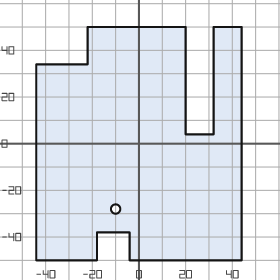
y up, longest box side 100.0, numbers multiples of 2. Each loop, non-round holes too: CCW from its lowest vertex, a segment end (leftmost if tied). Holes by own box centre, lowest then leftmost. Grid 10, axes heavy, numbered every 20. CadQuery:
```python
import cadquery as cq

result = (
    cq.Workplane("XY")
    .moveTo(-44.0, -50.0)
    .lineTo(-18.0, -50.0)
    .lineTo(-18.0, -38.0)
    .lineTo(-4.0, -38.0)
    .lineTo(-4.0, -50.0)
    .lineTo(44.0, -50.0)
    .lineTo(44.0, 50.0)
    .lineTo(32.0, 50.0)
    .lineTo(32.0, 4.0)
    .lineTo(20.0, 4.0)
    .lineTo(20.0, 50.0)
    .lineTo(-22.0, 50.0)
    .lineTo(-22.0, 34.0)
    .lineTo(-44.0, 34.0)
    .close()
    .moveTo(-10.0, -28.0)
    .circle(2.0)
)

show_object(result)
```